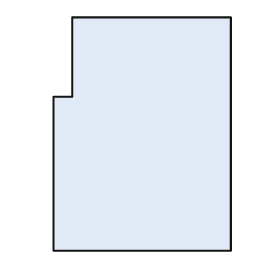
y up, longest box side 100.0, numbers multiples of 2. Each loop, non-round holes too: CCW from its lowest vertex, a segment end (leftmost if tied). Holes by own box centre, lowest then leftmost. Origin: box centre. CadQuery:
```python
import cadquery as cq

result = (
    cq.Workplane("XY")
    .moveTo(-38.0, -50.0)
    .lineTo(38.0, -50.0)
    .lineTo(38.0, 50.0)
    .lineTo(-30.0, 50.0)
    .lineTo(-30.0, 16.0)
    .lineTo(-38.0, 16.0)
    .close()
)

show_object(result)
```